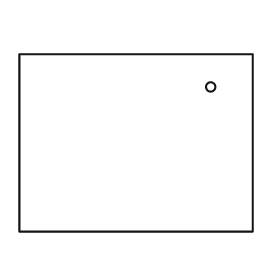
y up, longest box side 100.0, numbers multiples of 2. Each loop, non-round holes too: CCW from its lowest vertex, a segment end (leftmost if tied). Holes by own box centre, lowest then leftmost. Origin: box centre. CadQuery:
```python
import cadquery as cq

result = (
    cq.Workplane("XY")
    .moveTo(-50.0, -38.0)
    .lineTo(50.0, -38.0)
    .lineTo(50.0, 38.0)
    .lineTo(-50.0, 38.0)
    .close()
    .moveTo(32.0, 24.0)
    .circle(2.0)
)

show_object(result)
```